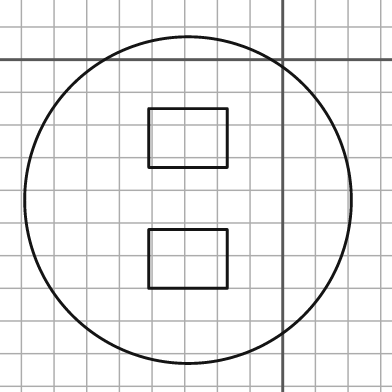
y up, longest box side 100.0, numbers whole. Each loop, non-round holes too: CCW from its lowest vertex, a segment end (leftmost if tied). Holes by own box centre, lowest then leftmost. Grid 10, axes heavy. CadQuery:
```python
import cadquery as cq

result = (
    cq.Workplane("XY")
    .moveTo(-29.0, -43.0)
    .circle(50.0)
    .moveTo(-41.0, -70.0)
    .lineTo(-17.0, -70.0)
    .lineTo(-17.0, -52.0)
    .lineTo(-41.0, -52.0)
    .close()
    .moveTo(-41.0, -33.0)
    .lineTo(-17.0, -33.0)
    .lineTo(-17.0, -15.0)
    .lineTo(-41.0, -15.0)
    .close()
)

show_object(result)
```